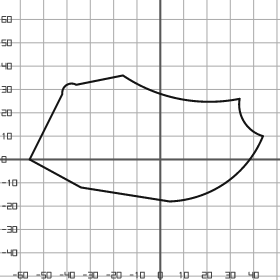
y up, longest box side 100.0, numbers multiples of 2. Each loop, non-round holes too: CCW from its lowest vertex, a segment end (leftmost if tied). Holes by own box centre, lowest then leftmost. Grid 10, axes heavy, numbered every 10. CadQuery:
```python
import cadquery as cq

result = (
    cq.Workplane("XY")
    .moveTo(4.0, -18.0)
    .threePointArc((28.0, -10.0), (44.0, 10.0))
    .threePointArc((36.0, 16.0), (34.0, 26.0))
    .threePointArc((8.0, 26.0), (-16.0, 36.0))
    .lineTo(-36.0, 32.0)
    .threePointArc((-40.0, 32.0), (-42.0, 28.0))
    .lineTo(-56.0, 0.0)
    .lineTo(-34.0, -12.0)
    .close()
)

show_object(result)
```